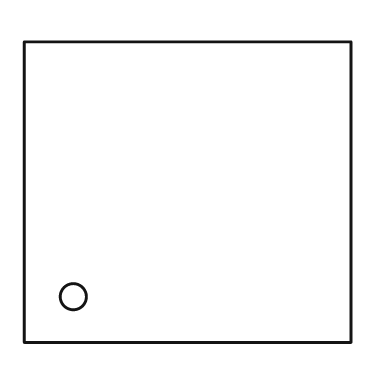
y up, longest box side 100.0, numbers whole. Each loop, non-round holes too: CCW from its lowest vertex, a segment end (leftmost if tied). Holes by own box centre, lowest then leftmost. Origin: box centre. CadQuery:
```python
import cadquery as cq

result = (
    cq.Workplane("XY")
    .moveTo(-50.0, -46.0)
    .lineTo(50.0, -46.0)
    .lineTo(50.0, 46.0)
    .lineTo(-50.0, 46.0)
    .close()
    .moveTo(-35.0, -32.0)
    .circle(4.0)
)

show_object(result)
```